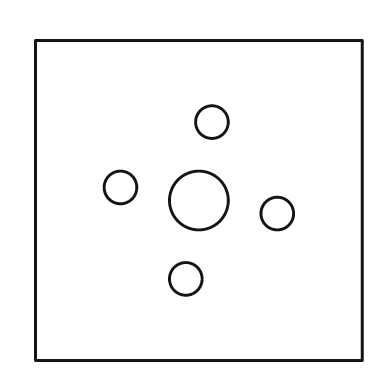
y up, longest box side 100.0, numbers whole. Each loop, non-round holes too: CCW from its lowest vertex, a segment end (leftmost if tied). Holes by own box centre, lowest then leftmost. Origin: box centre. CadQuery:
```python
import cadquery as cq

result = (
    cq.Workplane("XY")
    .moveTo(-50.0, -49.0)
    .lineTo(50.0, -49.0)
    .lineTo(50.0, 49.0)
    .lineTo(-50.0, 49.0)
    .close()
    .moveTo(-4.0, -24.0)
    .circle(5.0)
    .moveTo(24.0, -4.0)
    .circle(5.0)
    .moveTo(0.0, 0.0)
    .circle(9.0)
    .moveTo(-24.0, 4.0)
    .circle(5.0)
    .moveTo(4.0, 24.0)
    .circle(5.0)
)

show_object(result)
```